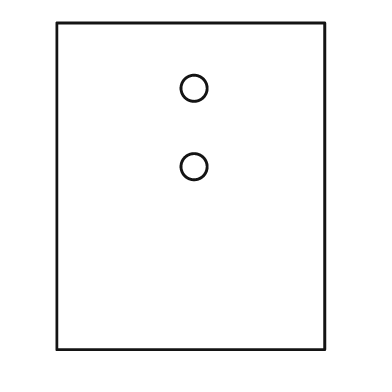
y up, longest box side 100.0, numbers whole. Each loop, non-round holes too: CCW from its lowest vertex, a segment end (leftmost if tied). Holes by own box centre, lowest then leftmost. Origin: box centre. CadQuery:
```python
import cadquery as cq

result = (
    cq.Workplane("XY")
    .moveTo(-41.0, -50.0)
    .lineTo(41.0, -50.0)
    .lineTo(41.0, 50.0)
    .lineTo(-41.0, 50.0)
    .close()
    .moveTo(1.0, 6.0)
    .circle(4.0)
    .moveTo(1.0, 30.0)
    .circle(4.0)
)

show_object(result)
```